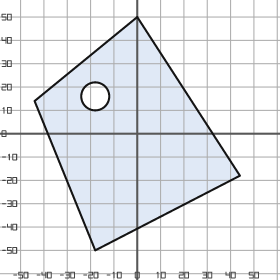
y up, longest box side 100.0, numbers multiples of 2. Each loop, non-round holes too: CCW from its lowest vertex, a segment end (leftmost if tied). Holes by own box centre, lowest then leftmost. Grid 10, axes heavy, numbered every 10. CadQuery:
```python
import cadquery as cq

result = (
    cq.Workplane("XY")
    .moveTo(-18.0, -50.0)
    .lineTo(44.0, -18.0)
    .lineTo(0.0, 50.0)
    .lineTo(-44.0, 14.0)
    .close()
    .moveTo(-18.0, 16.0)
    .circle(6.0)
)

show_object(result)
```